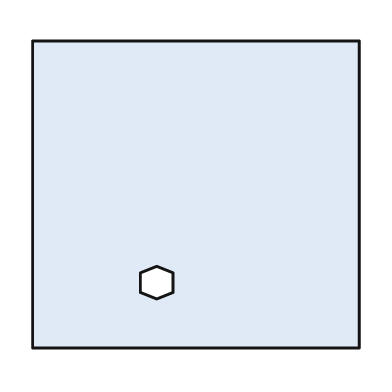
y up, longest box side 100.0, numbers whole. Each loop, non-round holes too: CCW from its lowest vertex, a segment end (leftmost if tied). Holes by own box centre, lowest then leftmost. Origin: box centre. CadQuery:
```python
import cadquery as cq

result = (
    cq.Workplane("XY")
    .moveTo(-50.0, -47.0)
    .lineTo(50.0, -47.0)
    .lineTo(50.0, 47.0)
    .lineTo(-50.0, 47.0)
    .close()
    .moveTo(-12.0, -32.0)
    .lineTo(-7.0, -30.0)
    .lineTo(-7.0, -24.0)
    .lineTo(-12.0, -22.0)
    .lineTo(-17.0, -24.0)
    .lineTo(-17.0, -30.0)
    .close()
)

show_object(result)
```